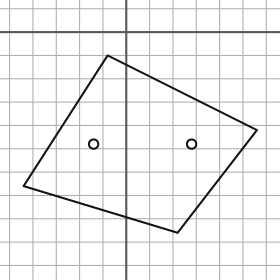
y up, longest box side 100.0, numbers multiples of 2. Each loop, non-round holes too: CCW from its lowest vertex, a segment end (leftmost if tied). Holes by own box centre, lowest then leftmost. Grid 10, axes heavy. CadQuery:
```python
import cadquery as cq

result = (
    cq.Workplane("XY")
    .moveTo(22.0, -86.0)
    .lineTo(56.0, -42.0)
    .lineTo(-8.0, -10.0)
    .lineTo(-44.0, -66.0)
    .close()
    .moveTo(-14.0, -48.0)
    .circle(2.0)
    .moveTo(28.0, -48.0)
    .circle(2.0)
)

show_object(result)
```